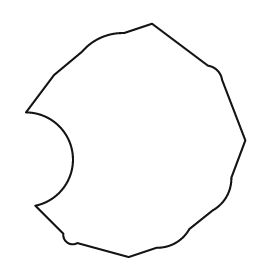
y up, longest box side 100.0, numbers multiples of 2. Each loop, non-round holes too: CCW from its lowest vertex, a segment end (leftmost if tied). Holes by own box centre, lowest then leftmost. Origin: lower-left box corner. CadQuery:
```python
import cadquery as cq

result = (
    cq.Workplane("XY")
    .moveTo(44.0, 0.0)
    .lineTo(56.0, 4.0)
    .threePointArc((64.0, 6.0), (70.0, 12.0))
    .lineTo(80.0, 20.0)
    .threePointArc((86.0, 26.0), (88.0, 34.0))
    .lineTo(94.0, 50.0)
    .lineTo(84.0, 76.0)
    .threePointArc((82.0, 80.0), (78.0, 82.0))
    .lineTo(54.0, 100.0)
    .lineTo(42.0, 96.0)
    .threePointArc((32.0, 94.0), (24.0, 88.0))
    .lineTo(12.0, 78.0)
    .lineTo(0.0, 62.0)
    .threePointArc((20.0, 44.0), (4.0, 22.0))
    .lineTo(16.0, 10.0)
    .threePointArc((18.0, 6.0), (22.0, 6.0))
    .close()
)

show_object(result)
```